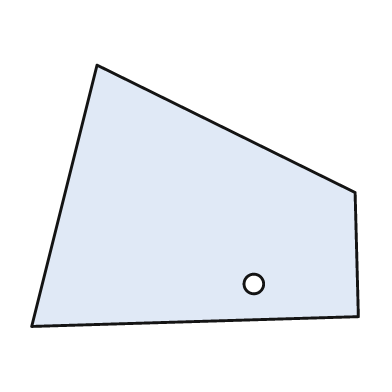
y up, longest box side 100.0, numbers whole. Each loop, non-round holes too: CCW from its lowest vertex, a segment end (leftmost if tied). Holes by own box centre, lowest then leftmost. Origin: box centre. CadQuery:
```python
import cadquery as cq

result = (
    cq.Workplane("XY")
    .moveTo(-50.0, -40.0)
    .lineTo(50.0, -37.0)
    .lineTo(49.0, 1.0)
    .lineTo(-30.0, 40.0)
    .close()
    .moveTo(18.0, -27.0)
    .circle(3.0)
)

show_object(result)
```